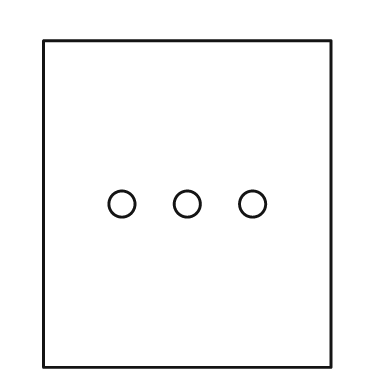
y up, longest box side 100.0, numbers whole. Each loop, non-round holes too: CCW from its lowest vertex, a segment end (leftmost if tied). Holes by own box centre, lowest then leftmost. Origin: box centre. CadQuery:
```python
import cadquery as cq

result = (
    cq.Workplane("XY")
    .moveTo(-44.0, -50.0)
    .lineTo(44.0, -50.0)
    .lineTo(44.0, 50.0)
    .lineTo(-44.0, 50.0)
    .close()
    .moveTo(-20.0, 0.0)
    .circle(4.0)
    .moveTo(0.0, 0.0)
    .circle(4.0)
    .moveTo(20.0, 0.0)
    .circle(4.0)
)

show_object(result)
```